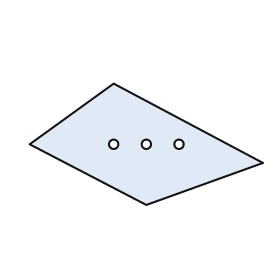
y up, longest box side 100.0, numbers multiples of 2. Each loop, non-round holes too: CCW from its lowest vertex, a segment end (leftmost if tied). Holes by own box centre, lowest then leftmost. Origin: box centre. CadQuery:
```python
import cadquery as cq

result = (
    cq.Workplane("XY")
    .moveTo(0.0, -26.0)
    .lineTo(50.0, -8.0)
    .lineTo(-14.0, 26.0)
    .lineTo(-50.0, 0.0)
    .close()
    .moveTo(-14.0, 0.0)
    .circle(2.0)
    .moveTo(0.0, 0.0)
    .circle(2.0)
    .moveTo(14.0, 0.0)
    .circle(2.0)
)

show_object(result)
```